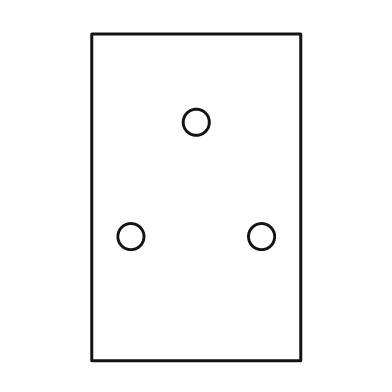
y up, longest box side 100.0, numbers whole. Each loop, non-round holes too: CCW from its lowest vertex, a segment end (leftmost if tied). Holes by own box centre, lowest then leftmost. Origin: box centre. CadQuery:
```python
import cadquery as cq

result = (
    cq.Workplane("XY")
    .moveTo(-32.0, -50.0)
    .lineTo(32.0, -50.0)
    .lineTo(32.0, 50.0)
    .lineTo(-32.0, 50.0)
    .close()
    .moveTo(-20.0, -12.0)
    .circle(4.0)
    .moveTo(20.0, -12.0)
    .circle(4.0)
    .moveTo(0.0, 23.0)
    .circle(4.0)
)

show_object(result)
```